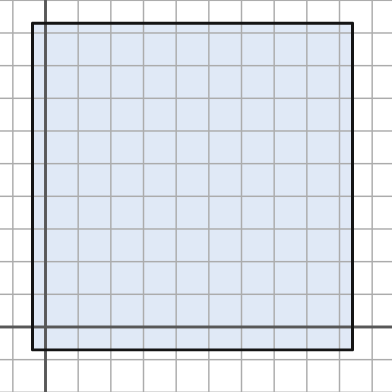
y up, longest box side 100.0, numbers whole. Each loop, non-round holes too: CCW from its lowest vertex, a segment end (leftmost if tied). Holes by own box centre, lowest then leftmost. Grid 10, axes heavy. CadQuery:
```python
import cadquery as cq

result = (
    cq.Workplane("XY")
    .moveTo(-4.0, -7.0)
    .lineTo(94.0, -7.0)
    .lineTo(94.0, 93.0)
    .lineTo(-4.0, 93.0)
    .close()
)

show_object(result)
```